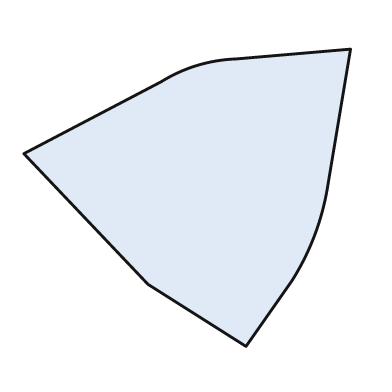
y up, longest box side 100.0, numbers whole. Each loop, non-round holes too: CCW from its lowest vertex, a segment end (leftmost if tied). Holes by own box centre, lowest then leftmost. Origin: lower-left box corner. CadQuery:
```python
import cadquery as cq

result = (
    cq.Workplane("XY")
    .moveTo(68.0, 0.0)
    .lineTo(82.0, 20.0)
    .threePointArc((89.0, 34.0), (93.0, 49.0))
    .lineTo(100.0, 91.0)
    .lineTo(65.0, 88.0)
    .threePointArc((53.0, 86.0), (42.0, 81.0))
    .lineTo(0.0, 59.0)
    .lineTo(38.0, 19.0)
    .close()
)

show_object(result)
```